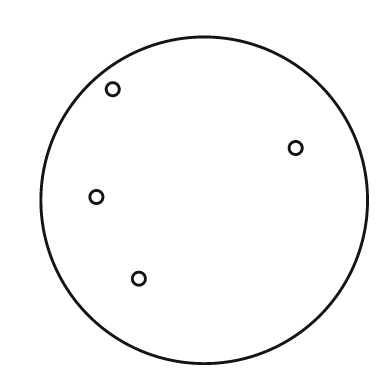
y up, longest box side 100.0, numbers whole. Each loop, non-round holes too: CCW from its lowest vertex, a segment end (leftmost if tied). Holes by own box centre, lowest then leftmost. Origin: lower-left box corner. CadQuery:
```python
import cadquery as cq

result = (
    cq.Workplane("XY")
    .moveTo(50.0, 50.0)
    .circle(50.0)
    .moveTo(30.0, 26.0)
    .circle(2.0)
    .moveTo(17.0, 51.0)
    .circle(2.0)
    .moveTo(78.0, 66.0)
    .circle(2.0)
    .moveTo(22.0, 84.0)
    .circle(2.0)
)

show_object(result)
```